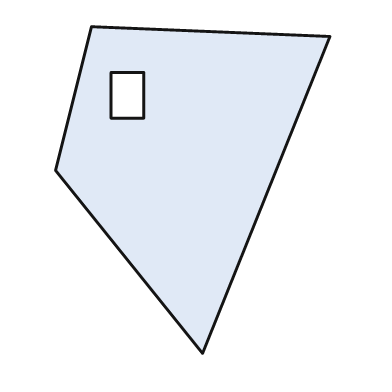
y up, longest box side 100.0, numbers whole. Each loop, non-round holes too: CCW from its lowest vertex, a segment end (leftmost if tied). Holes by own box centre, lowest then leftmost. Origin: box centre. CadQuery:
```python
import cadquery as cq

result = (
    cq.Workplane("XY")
    .moveTo(3.0, -50.0)
    .lineTo(42.0, 47.0)
    .lineTo(-31.0, 50.0)
    .lineTo(-42.0, 6.0)
    .close()
    .moveTo(-25.0, 22.0)
    .lineTo(-15.0, 22.0)
    .lineTo(-15.0, 36.0)
    .lineTo(-25.0, 36.0)
    .close()
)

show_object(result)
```